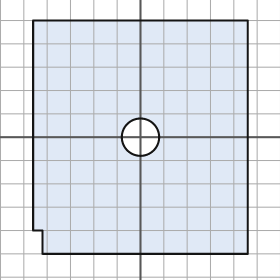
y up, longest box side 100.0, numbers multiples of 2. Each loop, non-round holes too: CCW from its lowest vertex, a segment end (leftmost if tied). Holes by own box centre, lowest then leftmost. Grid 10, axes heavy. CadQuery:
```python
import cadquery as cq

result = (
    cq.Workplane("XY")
    .moveTo(-42.0, -50.0)
    .lineTo(46.0, -50.0)
    .lineTo(46.0, 50.0)
    .lineTo(-46.0, 50.0)
    .lineTo(-46.0, -40.0)
    .lineTo(-42.0, -40.0)
    .close()
    .moveTo(0.0, 0.0)
    .circle(8.0)
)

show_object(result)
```